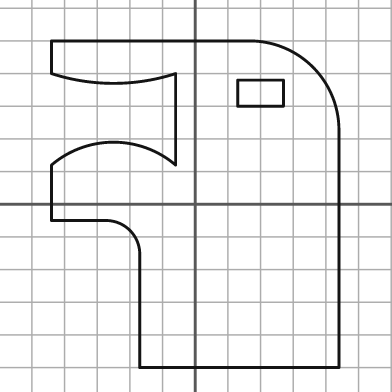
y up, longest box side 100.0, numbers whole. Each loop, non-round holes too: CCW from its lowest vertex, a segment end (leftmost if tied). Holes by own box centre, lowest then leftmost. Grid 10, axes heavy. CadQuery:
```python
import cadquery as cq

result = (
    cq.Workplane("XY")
    .moveTo(-17.0, -50.0)
    .lineTo(44.0, -50.0)
    .lineTo(44.0, 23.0)
    .threePointArc((36.0, 42.0), (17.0, 50.0))
    .lineTo(-44.0, 50.0)
    .lineTo(-44.0, 40.0)
    .threePointArc((-25.0, 37.0), (-6.0, 40.0))
    .lineTo(-6.0, 12.0)
    .threePointArc((-25.0, 19.0), (-44.0, 12.0))
    .lineTo(-44.0, -5.0)
    .lineTo(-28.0, -5.0)
    .threePointArc((-20.0, -8.0), (-17.0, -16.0))
    .close()
    .moveTo(13.0, 30.0)
    .lineTo(27.0, 30.0)
    .lineTo(27.0, 38.0)
    .lineTo(13.0, 38.0)
    .close()
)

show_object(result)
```